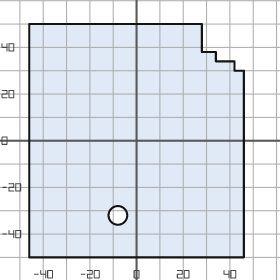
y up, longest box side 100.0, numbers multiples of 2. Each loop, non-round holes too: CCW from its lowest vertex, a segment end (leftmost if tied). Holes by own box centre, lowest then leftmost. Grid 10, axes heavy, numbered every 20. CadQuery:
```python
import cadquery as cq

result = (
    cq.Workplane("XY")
    .moveTo(-46.0, -50.0)
    .lineTo(46.0, -50.0)
    .lineTo(46.0, 30.0)
    .lineTo(42.0, 30.0)
    .lineTo(42.0, 34.0)
    .lineTo(34.0, 34.0)
    .lineTo(34.0, 38.0)
    .lineTo(28.0, 38.0)
    .lineTo(28.0, 50.0)
    .lineTo(-46.0, 50.0)
    .close()
    .moveTo(-8.0, -32.0)
    .circle(4.0)
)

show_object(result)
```